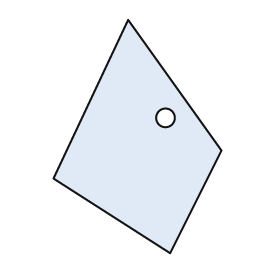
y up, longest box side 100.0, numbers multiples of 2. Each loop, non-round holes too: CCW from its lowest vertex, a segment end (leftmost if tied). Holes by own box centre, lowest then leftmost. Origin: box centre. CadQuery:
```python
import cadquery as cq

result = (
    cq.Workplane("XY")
    .moveTo(14.0, -50.0)
    .lineTo(36.0, -6.0)
    .lineTo(-4.0, 50.0)
    .lineTo(-36.0, -18.0)
    .close()
    .moveTo(12.0, 8.0)
    .circle(4.0)
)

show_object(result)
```